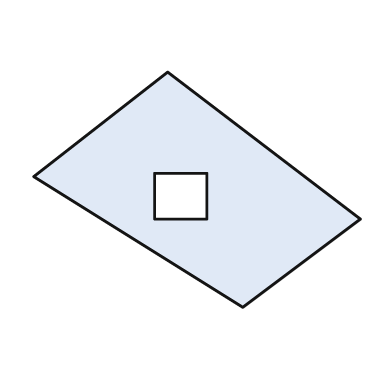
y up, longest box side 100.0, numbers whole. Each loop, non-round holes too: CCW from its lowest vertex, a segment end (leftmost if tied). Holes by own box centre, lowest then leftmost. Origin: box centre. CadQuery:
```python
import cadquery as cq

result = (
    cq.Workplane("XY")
    .moveTo(14.0, -36.0)
    .lineTo(50.0, -9.0)
    .lineTo(-9.0, 36.0)
    .lineTo(-50.0, 4.0)
    .close()
    .moveTo(-13.0, -9.0)
    .lineTo(3.0, -9.0)
    .lineTo(3.0, 5.0)
    .lineTo(-13.0, 5.0)
    .close()
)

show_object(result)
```